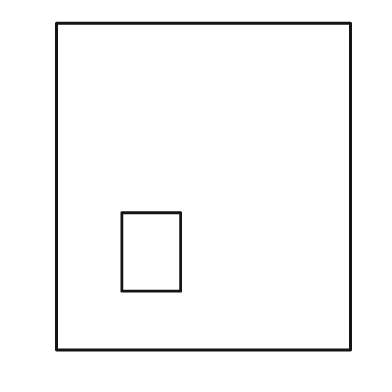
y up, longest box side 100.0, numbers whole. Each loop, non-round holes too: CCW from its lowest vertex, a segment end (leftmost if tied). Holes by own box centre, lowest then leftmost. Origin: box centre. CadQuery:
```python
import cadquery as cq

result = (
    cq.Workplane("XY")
    .moveTo(-45.0, -50.0)
    .lineTo(45.0, -50.0)
    .lineTo(45.0, 50.0)
    .lineTo(-45.0, 50.0)
    .close()
    .moveTo(-25.0, -32.0)
    .lineTo(-7.0, -32.0)
    .lineTo(-7.0, -8.0)
    .lineTo(-25.0, -8.0)
    .close()
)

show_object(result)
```